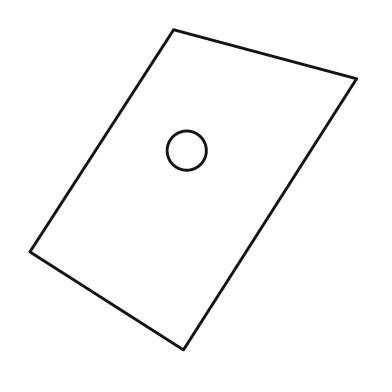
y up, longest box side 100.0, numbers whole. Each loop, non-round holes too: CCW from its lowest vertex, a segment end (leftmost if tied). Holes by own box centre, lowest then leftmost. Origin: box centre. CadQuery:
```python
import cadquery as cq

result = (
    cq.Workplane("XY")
    .moveTo(-3.0, -49.0)
    .lineTo(50.0, 34.0)
    .lineTo(-6.0, 49.0)
    .lineTo(-50.0, -19.0)
    .close()
    .moveTo(-2.0, 12.0)
    .circle(6.0)
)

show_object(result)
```